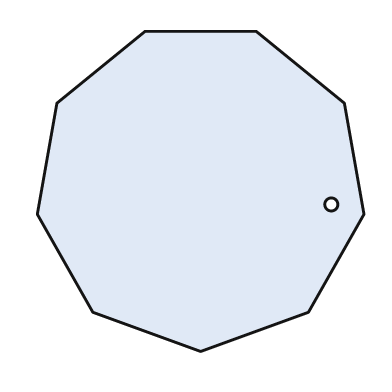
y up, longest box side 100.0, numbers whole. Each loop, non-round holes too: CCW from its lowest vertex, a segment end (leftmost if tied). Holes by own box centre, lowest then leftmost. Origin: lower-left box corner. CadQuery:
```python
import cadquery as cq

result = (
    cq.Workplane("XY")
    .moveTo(50.0, 0.0)
    .lineTo(83.0, 12.0)
    .lineTo(100.0, 42.0)
    .lineTo(94.0, 76.0)
    .lineTo(67.0, 98.0)
    .lineTo(33.0, 98.0)
    .lineTo(6.0, 76.0)
    .lineTo(0.0, 42.0)
    .lineTo(17.0, 12.0)
    .close()
    .moveTo(90.0, 45.0)
    .circle(2.0)
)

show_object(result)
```